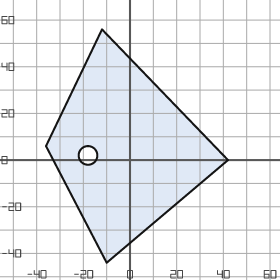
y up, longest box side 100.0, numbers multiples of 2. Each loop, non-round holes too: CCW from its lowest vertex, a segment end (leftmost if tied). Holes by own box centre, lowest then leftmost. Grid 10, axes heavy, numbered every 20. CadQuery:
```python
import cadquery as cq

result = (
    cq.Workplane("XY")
    .moveTo(-10.0, -44.0)
    .lineTo(42.0, 0.0)
    .lineTo(-12.0, 56.0)
    .lineTo(-36.0, 6.0)
    .close()
    .moveTo(-18.0, 2.0)
    .circle(4.0)
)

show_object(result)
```